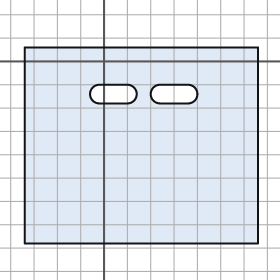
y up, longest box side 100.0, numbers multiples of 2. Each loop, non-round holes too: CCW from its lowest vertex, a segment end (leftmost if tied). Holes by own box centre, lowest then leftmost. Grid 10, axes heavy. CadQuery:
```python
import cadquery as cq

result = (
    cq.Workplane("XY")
    .moveTo(-34.0, -78.0)
    .lineTo(66.0, -78.0)
    .lineTo(66.0, 6.0)
    .lineTo(-34.0, 6.0)
    .close()
    .moveTo(-2.0, -18.0)
    .lineTo(10.0, -18.0)
    .threePointArc((14.0, -14.0), (10.0, -10.0))
    .lineTo(-2.0, -10.0)
    .threePointArc((-6.0, -14.0), (-2.0, -18.0))
    .close()
    .moveTo(24.0, -18.0)
    .lineTo(36.0, -18.0)
    .threePointArc((40.0, -14.0), (36.0, -10.0))
    .lineTo(24.0, -10.0)
    .threePointArc((20.0, -14.0), (24.0, -18.0))
    .close()
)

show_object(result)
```